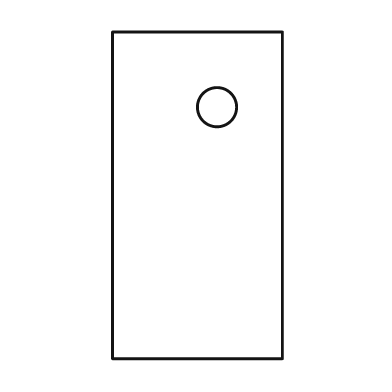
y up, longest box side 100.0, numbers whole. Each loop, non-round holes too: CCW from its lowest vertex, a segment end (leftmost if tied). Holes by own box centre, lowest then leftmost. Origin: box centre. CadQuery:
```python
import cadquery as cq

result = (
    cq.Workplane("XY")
    .moveTo(-26.0, -50.0)
    .lineTo(26.0, -50.0)
    .lineTo(26.0, 50.0)
    .lineTo(-26.0, 50.0)
    .close()
    .moveTo(6.0, 27.0)
    .circle(6.0)
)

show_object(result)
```